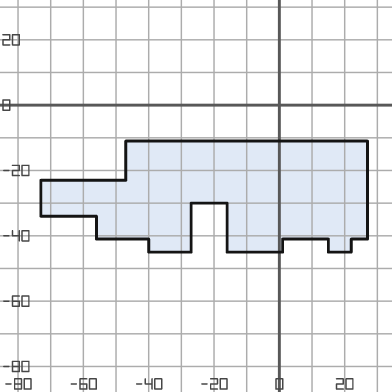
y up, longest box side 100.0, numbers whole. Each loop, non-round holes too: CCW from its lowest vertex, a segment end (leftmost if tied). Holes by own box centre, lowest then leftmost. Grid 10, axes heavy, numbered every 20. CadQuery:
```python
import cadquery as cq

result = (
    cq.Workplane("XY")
    .moveTo(-40.0, -45.0)
    .lineTo(-27.0, -45.0)
    .lineTo(-27.0, -30.0)
    .lineTo(-16.0, -30.0)
    .lineTo(-16.0, -45.0)
    .lineTo(1.0, -45.0)
    .lineTo(1.0, -41.0)
    .lineTo(15.0, -41.0)
    .lineTo(15.0, -45.0)
    .lineTo(22.0, -45.0)
    .lineTo(22.0, -41.0)
    .lineTo(27.0, -41.0)
    .lineTo(27.0, -11.0)
    .lineTo(-47.0, -11.0)
    .lineTo(-47.0, -23.0)
    .lineTo(-73.0, -23.0)
    .lineTo(-73.0, -34.0)
    .lineTo(-56.0, -34.0)
    .lineTo(-56.0, -41.0)
    .lineTo(-40.0, -41.0)
    .close()
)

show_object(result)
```